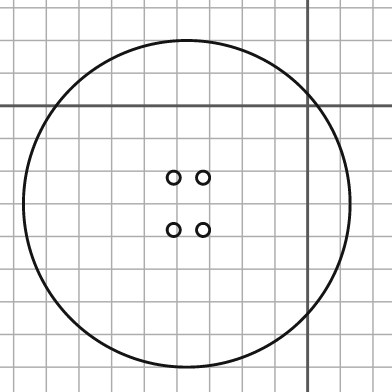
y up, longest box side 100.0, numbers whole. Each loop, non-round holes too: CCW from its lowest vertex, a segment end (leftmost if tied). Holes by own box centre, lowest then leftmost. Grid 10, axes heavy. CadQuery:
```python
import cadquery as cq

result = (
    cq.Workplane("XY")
    .moveTo(-37.0, -30.0)
    .circle(50.0)
    .moveTo(-41.0, -38.0)
    .circle(2.0)
    .moveTo(-32.0, -38.0)
    .circle(2.0)
    .moveTo(-41.0, -22.0)
    .circle(2.0)
    .moveTo(-32.0, -22.0)
    .circle(2.0)
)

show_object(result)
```